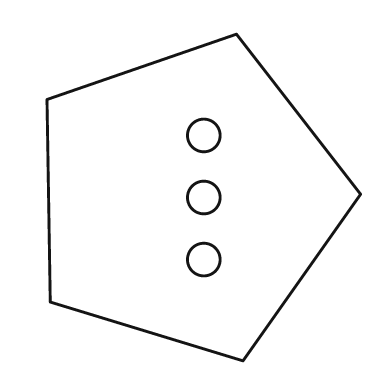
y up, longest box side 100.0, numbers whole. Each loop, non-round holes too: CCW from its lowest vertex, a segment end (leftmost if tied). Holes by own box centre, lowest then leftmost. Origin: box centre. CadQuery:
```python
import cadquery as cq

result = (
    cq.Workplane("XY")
    .moveTo(12.0, -50.0)
    .lineTo(48.0, 1.0)
    .lineTo(10.0, 50.0)
    .lineTo(-48.0, 30.0)
    .lineTo(-47.0, -32.0)
    .close()
    .moveTo(0.0, -19.0)
    .circle(5.0)
    .moveTo(0.0, 0.0)
    .circle(5.0)
    .moveTo(0.0, 19.0)
    .circle(5.0)
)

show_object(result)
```